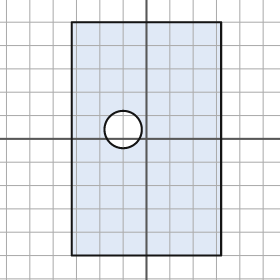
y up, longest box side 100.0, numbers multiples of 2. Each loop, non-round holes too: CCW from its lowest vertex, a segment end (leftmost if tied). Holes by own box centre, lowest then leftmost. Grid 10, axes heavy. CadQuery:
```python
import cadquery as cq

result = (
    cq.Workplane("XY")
    .moveTo(-32.0, -50.0)
    .lineTo(32.0, -50.0)
    .lineTo(32.0, 50.0)
    .lineTo(-32.0, 50.0)
    .close()
    .moveTo(-10.0, 4.0)
    .circle(8.0)
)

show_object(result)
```